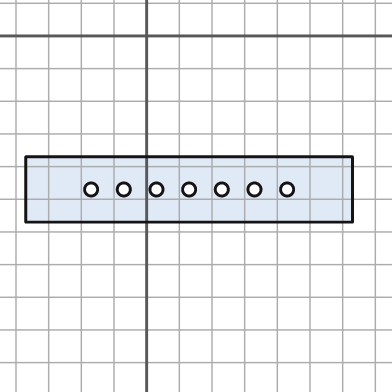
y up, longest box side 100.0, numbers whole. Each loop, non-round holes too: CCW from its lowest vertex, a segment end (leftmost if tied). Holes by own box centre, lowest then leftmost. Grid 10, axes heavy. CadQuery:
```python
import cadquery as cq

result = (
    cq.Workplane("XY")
    .moveTo(-37.0, -57.0)
    .lineTo(63.0, -57.0)
    .lineTo(63.0, -37.0)
    .lineTo(-37.0, -37.0)
    .close()
    .moveTo(-17.0, -47.0)
    .circle(2.0)
    .moveTo(-7.0, -47.0)
    .circle(2.0)
    .moveTo(3.0, -47.0)
    .circle(2.0)
    .moveTo(13.0, -47.0)
    .circle(2.0)
    .moveTo(23.0, -47.0)
    .circle(2.0)
    .moveTo(33.0, -47.0)
    .circle(2.0)
    .moveTo(43.0, -47.0)
    .circle(2.0)
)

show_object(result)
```